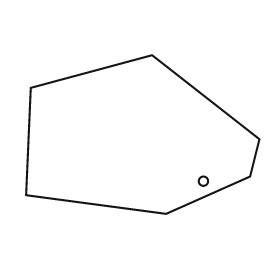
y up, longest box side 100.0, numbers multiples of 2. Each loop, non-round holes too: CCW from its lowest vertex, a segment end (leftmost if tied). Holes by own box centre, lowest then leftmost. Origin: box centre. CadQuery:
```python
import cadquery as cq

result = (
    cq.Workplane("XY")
    .moveTo(10.0, -34.0)
    .lineTo(46.0, -18.0)
    .lineTo(50.0, -2.0)
    .lineTo(4.0, 34.0)
    .lineTo(-48.0, 20.0)
    .lineTo(-50.0, -26.0)
    .close()
    .moveTo(26.0, -20.0)
    .circle(2.0)
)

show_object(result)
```